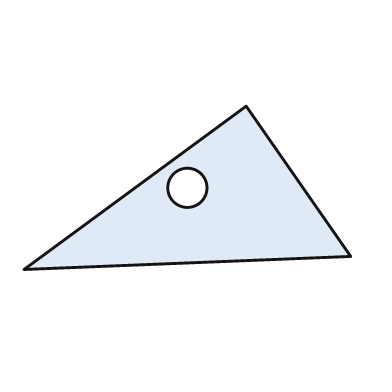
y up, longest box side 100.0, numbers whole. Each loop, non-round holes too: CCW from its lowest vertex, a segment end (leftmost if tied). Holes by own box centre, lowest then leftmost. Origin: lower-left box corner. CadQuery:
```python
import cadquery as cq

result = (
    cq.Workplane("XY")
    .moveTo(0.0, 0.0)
    .lineTo(100.0, 4.0)
    .lineTo(68.0, 50.0)
    .close()
    .moveTo(50.0, 25.0)
    .circle(6.0)
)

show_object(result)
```